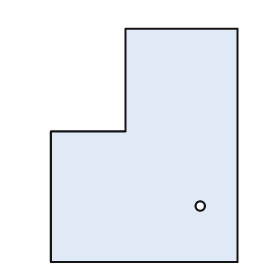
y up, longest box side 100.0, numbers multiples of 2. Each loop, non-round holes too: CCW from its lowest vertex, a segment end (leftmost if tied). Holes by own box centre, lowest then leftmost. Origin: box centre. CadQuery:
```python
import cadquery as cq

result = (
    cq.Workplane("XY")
    .moveTo(-40.0, -50.0)
    .lineTo(40.0, -50.0)
    .lineTo(40.0, 50.0)
    .lineTo(-8.0, 50.0)
    .lineTo(-8.0, 6.0)
    .lineTo(-40.0, 6.0)
    .close()
    .moveTo(24.0, -26.0)
    .circle(2.0)
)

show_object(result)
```